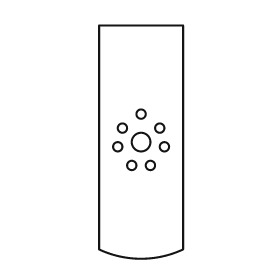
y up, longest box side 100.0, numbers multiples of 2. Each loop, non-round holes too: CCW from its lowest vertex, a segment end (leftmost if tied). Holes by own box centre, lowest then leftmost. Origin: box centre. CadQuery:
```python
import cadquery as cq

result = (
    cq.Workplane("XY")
    .moveTo(-18.0, -46.0)
    .threePointArc((0.0, -50.0), (18.0, -46.0))
    .lineTo(18.0, 50.0)
    .lineTo(-18.0, 50.0)
    .close()
    .moveTo(-4.0, -10.0)
    .circle(2.0)
    .moveTo(4.0, -10.0)
    .circle(2.0)
    .moveTo(-10.0, -2.0)
    .circle(2.0)
    .moveTo(10.0, -2.0)
    .circle(2.0)
    .moveTo(0.0, 0.0)
    .circle(4.0)
    .moveTo(-8.0, 6.0)
    .circle(2.0)
    .moveTo(8.0, 6.0)
    .circle(2.0)
    .moveTo(0.0, 12.0)
    .circle(2.0)
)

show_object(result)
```